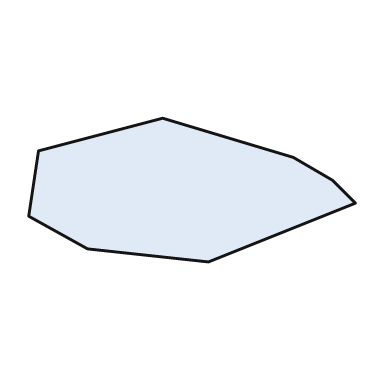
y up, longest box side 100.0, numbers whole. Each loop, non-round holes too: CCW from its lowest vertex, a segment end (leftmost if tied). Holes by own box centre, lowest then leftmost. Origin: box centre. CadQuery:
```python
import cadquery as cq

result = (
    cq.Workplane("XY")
    .moveTo(5.0, -22.0)
    .lineTo(50.0, -4.0)
    .lineTo(43.0, 3.0)
    .lineTo(31.0, 10.0)
    .lineTo(-9.0, 22.0)
    .lineTo(-47.0, 12.0)
    .lineTo(-50.0, -8.0)
    .lineTo(-32.0, -18.0)
    .close()
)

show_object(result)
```